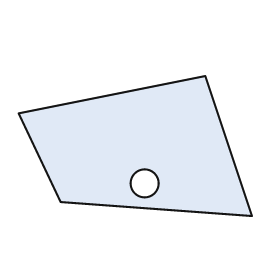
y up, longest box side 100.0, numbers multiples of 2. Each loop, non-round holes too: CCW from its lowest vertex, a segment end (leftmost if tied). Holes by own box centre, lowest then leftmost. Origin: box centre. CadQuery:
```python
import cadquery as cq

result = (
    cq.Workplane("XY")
    .moveTo(50.0, -30.0)
    .lineTo(30.0, 30.0)
    .lineTo(-50.0, 14.0)
    .lineTo(-32.0, -24.0)
    .close()
    .moveTo(4.0, -16.0)
    .circle(6.0)
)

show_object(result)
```